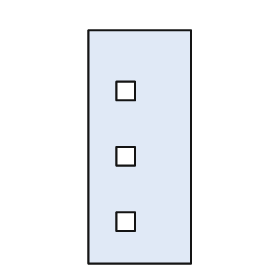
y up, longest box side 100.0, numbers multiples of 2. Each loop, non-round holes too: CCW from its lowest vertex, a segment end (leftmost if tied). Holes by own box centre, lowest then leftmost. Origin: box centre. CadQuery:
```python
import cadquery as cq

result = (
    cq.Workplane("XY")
    .moveTo(-22.0, -50.0)
    .lineTo(22.0, -50.0)
    .lineTo(22.0, 50.0)
    .lineTo(-22.0, 50.0)
    .close()
    .moveTo(-10.0, -36.0)
    .lineTo(-2.0, -36.0)
    .lineTo(-2.0, -28.0)
    .lineTo(-10.0, -28.0)
    .close()
    .moveTo(-10.0, -8.0)
    .lineTo(-2.0, -8.0)
    .lineTo(-2.0, 0.0)
    .lineTo(-10.0, 0.0)
    .close()
    .moveTo(-10.0, 20.0)
    .lineTo(-2.0, 20.0)
    .lineTo(-2.0, 28.0)
    .lineTo(-10.0, 28.0)
    .close()
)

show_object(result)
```